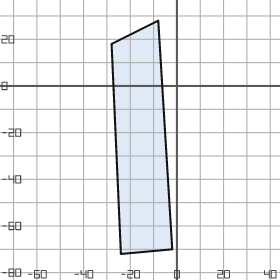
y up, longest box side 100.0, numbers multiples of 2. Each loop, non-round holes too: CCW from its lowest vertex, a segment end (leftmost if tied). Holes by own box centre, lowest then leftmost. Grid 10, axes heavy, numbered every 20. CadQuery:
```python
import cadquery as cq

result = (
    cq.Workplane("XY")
    .moveTo(-24.0, -72.0)
    .lineTo(-2.0, -70.0)
    .lineTo(-8.0, 28.0)
    .lineTo(-28.0, 18.0)
    .close()
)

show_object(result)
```